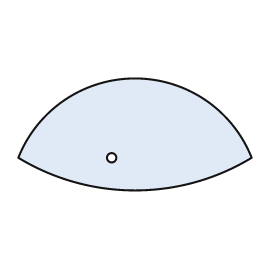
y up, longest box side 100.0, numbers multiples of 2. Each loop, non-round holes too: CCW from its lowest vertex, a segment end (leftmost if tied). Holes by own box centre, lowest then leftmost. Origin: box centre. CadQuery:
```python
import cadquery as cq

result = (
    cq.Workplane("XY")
    .moveTo(-50.0, -10.0)
    .threePointArc((0.0, -24.0), (50.0, -10.0))
    .threePointArc((0.0, 24.0), (-50.0, -10.0))
    .close()
    .moveTo(-10.0, -10.0)
    .circle(2.0)
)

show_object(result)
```